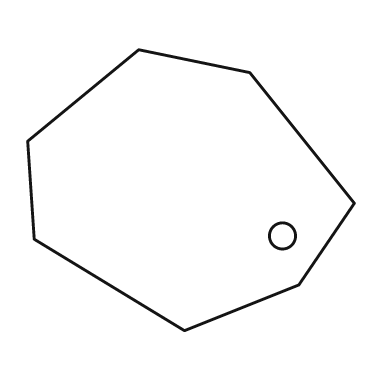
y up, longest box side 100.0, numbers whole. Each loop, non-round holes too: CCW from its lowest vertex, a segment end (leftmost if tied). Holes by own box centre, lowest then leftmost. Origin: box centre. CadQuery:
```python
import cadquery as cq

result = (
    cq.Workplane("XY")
    .moveTo(-2.0, -43.0)
    .lineTo(33.0, -29.0)
    .lineTo(50.0, -4.0)
    .lineTo(18.0, 36.0)
    .lineTo(-16.0, 43.0)
    .lineTo(-50.0, 15.0)
    .lineTo(-48.0, -15.0)
    .close()
    .moveTo(28.0, -14.0)
    .circle(4.0)
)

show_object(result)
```